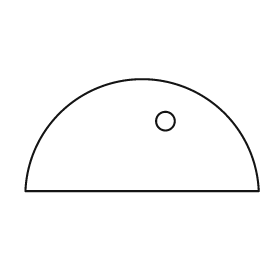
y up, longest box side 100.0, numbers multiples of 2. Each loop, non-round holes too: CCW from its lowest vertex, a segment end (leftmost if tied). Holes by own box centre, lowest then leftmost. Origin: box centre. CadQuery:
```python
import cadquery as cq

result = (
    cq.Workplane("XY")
    .moveTo(-50.0, -24.0)
    .lineTo(50.0, -24.0)
    .threePointArc((0.0, 24.0), (-50.0, -24.0))
    .close()
    .moveTo(10.0, 6.0)
    .circle(4.0)
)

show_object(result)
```